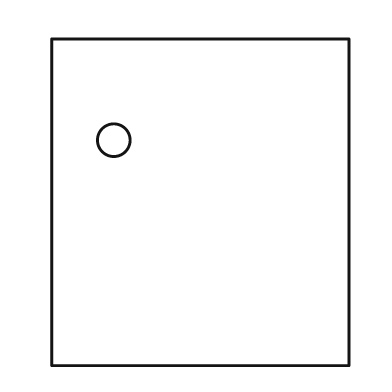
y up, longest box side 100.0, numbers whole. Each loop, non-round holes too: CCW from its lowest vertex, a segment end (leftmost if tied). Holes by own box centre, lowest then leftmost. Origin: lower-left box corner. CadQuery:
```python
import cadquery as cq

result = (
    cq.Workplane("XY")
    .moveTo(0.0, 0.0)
    .lineTo(91.0, 0.0)
    .lineTo(91.0, 100.0)
    .lineTo(0.0, 100.0)
    .close()
    .moveTo(19.0, 69.0)
    .circle(5.0)
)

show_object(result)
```